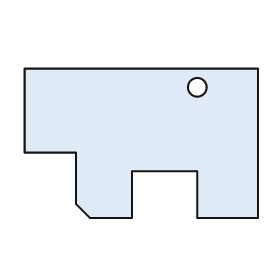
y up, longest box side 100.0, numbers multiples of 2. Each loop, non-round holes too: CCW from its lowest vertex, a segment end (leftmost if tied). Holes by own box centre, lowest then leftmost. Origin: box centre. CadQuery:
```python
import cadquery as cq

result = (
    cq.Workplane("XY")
    .moveTo(-22.0, -32.0)
    .lineTo(-4.0, -32.0)
    .lineTo(-4.0, -12.0)
    .lineTo(24.0, -12.0)
    .lineTo(24.0, -32.0)
    .lineTo(50.0, -32.0)
    .lineTo(50.0, 32.0)
    .lineTo(-50.0, 32.0)
    .lineTo(-50.0, -4.0)
    .lineTo(-28.0, -4.0)
    .lineTo(-28.0, -26.0)
    .close()
    .moveTo(24.0, 24.0)
    .circle(4.0)
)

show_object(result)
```